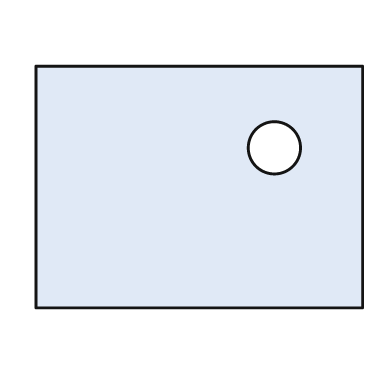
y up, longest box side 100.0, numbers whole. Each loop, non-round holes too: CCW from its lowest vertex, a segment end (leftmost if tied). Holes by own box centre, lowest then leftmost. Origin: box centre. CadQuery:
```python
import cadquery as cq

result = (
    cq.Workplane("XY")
    .moveTo(-50.0, -37.0)
    .lineTo(50.0, -37.0)
    .lineTo(50.0, 37.0)
    .lineTo(-50.0, 37.0)
    .close()
    .moveTo(23.0, 12.0)
    .circle(8.0)
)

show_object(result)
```